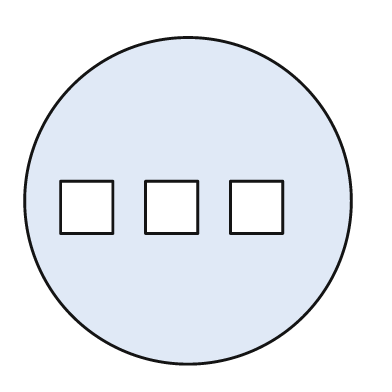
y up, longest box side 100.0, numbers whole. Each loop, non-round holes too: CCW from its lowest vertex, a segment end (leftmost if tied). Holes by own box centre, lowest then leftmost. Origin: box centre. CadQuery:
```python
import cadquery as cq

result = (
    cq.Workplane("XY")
    .moveTo(0.0, 0.0)
    .circle(50.0)
    .moveTo(-39.0, -10.0)
    .lineTo(-23.0, -10.0)
    .lineTo(-23.0, 6.0)
    .lineTo(-39.0, 6.0)
    .close()
    .moveTo(-13.0, -10.0)
    .lineTo(3.0, -10.0)
    .lineTo(3.0, 6.0)
    .lineTo(-13.0, 6.0)
    .close()
    .moveTo(13.0, -10.0)
    .lineTo(29.0, -10.0)
    .lineTo(29.0, 6.0)
    .lineTo(13.0, 6.0)
    .close()
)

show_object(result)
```